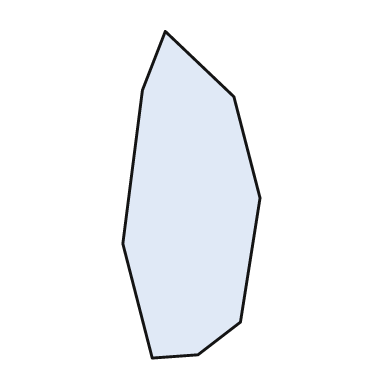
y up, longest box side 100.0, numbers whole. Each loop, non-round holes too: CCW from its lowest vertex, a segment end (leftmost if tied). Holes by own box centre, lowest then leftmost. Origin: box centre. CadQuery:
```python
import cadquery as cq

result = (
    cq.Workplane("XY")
    .moveTo(-12.0, -50.0)
    .lineTo(2.0, -49.0)
    .lineTo(15.0, -39.0)
    .lineTo(21.0, -1.0)
    .lineTo(13.0, 30.0)
    .lineTo(-8.0, 50.0)
    .lineTo(-15.0, 32.0)
    .lineTo(-21.0, -15.0)
    .close()
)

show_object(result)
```